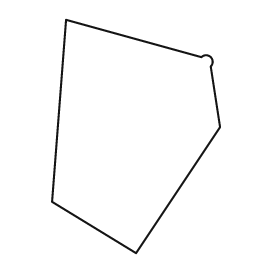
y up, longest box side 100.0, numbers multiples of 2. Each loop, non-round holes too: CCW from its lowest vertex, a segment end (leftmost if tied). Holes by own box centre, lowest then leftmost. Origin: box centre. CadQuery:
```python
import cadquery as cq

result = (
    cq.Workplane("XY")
    .moveTo(0.0, -50.0)
    .lineTo(36.0, 4.0)
    .lineTo(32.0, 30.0)
    .threePointArc((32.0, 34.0), (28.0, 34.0))
    .lineTo(-30.0, 50.0)
    .lineTo(-36.0, -28.0)
    .close()
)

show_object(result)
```